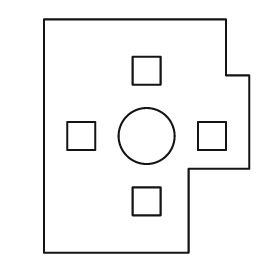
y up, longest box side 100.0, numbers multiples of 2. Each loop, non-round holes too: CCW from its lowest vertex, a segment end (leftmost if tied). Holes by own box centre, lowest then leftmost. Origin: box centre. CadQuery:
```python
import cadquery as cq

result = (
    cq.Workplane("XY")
    .moveTo(-44.0, -50.0)
    .lineTo(18.0, -50.0)
    .lineTo(18.0, -14.0)
    .lineTo(44.0, -14.0)
    .lineTo(44.0, 26.0)
    .lineTo(34.0, 26.0)
    .lineTo(34.0, 50.0)
    .lineTo(-44.0, 50.0)
    .close()
    .moveTo(-6.0, -34.0)
    .lineTo(6.0, -34.0)
    .lineTo(6.0, -22.0)
    .lineTo(-6.0, -22.0)
    .close()
    .moveTo(-34.0, -6.0)
    .lineTo(-22.0, -6.0)
    .lineTo(-22.0, 6.0)
    .lineTo(-34.0, 6.0)
    .close()
    .moveTo(0.0, 0.0)
    .circle(12.0)
    .moveTo(22.0, -6.0)
    .lineTo(34.0, -6.0)
    .lineTo(34.0, 6.0)
    .lineTo(22.0, 6.0)
    .close()
    .moveTo(-6.0, 22.0)
    .lineTo(6.0, 22.0)
    .lineTo(6.0, 34.0)
    .lineTo(-6.0, 34.0)
    .close()
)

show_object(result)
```